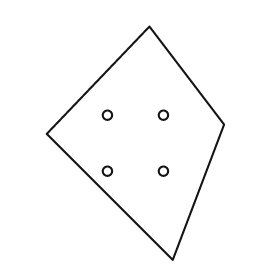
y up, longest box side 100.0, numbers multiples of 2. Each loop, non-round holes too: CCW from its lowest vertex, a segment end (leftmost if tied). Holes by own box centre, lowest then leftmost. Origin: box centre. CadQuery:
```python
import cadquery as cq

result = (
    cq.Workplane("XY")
    .moveTo(16.0, -50.0)
    .lineTo(38.0, 8.0)
    .lineTo(6.0, 50.0)
    .lineTo(-38.0, 4.0)
    .close()
    .moveTo(-12.0, -12.0)
    .circle(2.0)
    .moveTo(12.0, -12.0)
    .circle(2.0)
    .moveTo(-12.0, 12.0)
    .circle(2.0)
    .moveTo(12.0, 12.0)
    .circle(2.0)
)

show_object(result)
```